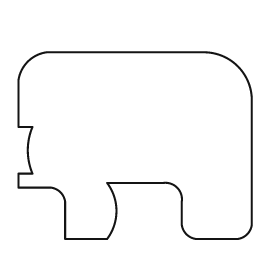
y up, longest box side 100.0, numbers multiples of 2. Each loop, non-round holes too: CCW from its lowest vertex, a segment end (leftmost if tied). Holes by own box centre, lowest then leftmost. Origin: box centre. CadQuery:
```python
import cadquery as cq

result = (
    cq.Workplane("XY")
    .moveTo(-30.0, -40.0)
    .lineTo(-12.0, -40.0)
    .threePointArc((-8.0, -28.0), (-12.0, -16.0))
    .lineTo(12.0, -16.0)
    .threePointArc((18.0, -18.0), (20.0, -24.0))
    .lineTo(20.0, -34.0)
    .threePointArc((22.0, -38.0), (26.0, -40.0))
    .lineTo(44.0, -40.0)
    .threePointArc((48.0, -38.0), (50.0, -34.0))
    .lineTo(50.0, 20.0)
    .threePointArc((44.0, 34.0), (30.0, 40.0))
    .lineTo(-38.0, 40.0)
    .threePointArc((-46.0, 36.0), (-50.0, 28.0))
    .lineTo(-50.0, 8.0)
    .lineTo(-44.0, 8.0)
    .threePointArc((-46.0, -2.0), (-44.0, -12.0))
    .lineTo(-50.0, -12.0)
    .lineTo(-50.0, -18.0)
    .lineTo(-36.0, -18.0)
    .threePointArc((-32.0, -20.0), (-30.0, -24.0))
    .close()
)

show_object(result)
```